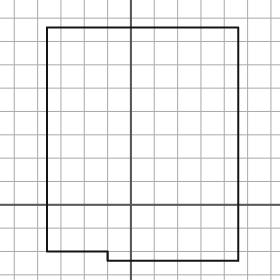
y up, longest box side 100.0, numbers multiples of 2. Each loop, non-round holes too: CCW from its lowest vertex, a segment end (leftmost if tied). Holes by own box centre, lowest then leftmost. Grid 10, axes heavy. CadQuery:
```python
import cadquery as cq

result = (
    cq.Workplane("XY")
    .moveTo(-10.0, -24.0)
    .lineTo(46.0, -24.0)
    .lineTo(46.0, 76.0)
    .lineTo(-36.0, 76.0)
    .lineTo(-36.0, -20.0)
    .lineTo(-10.0, -20.0)
    .close()
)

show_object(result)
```